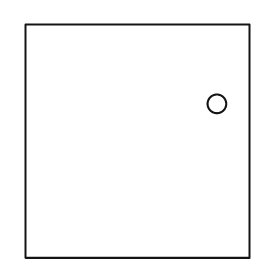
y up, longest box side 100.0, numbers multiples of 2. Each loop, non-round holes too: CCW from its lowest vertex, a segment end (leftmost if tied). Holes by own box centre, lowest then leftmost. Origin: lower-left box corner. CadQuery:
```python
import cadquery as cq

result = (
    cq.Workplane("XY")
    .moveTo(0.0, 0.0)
    .lineTo(96.0, 0.0)
    .lineTo(96.0, 100.0)
    .lineTo(0.0, 100.0)
    .close()
    .moveTo(82.0, 66.0)
    .circle(4.0)
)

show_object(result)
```